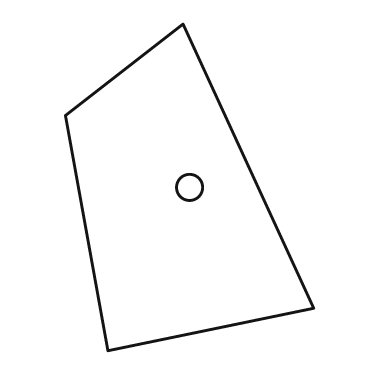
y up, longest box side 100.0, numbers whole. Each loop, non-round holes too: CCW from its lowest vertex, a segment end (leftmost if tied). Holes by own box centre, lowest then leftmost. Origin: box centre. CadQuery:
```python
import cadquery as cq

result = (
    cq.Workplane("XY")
    .moveTo(-25.0, -50.0)
    .lineTo(38.0, -37.0)
    .lineTo(-2.0, 50.0)
    .lineTo(-38.0, 22.0)
    .close()
    .moveTo(0.0, 0.0)
    .circle(4.0)
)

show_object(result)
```